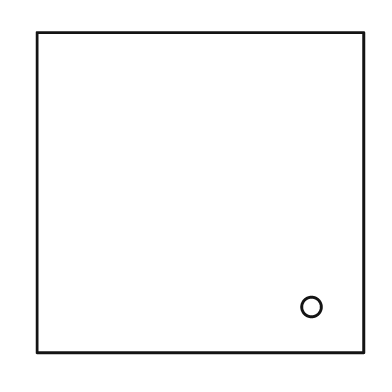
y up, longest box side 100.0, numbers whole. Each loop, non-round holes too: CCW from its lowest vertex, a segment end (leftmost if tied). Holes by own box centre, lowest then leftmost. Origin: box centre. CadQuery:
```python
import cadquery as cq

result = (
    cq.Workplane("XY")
    .moveTo(-50.0, -49.0)
    .lineTo(50.0, -49.0)
    .lineTo(50.0, 49.0)
    .lineTo(-50.0, 49.0)
    .close()
    .moveTo(34.0, -35.0)
    .circle(3.0)
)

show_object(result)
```